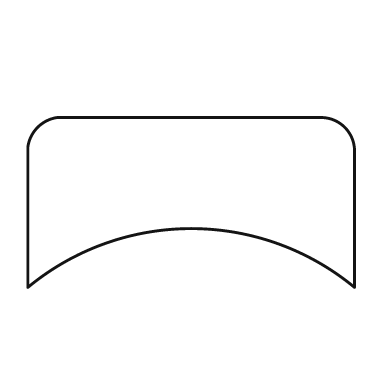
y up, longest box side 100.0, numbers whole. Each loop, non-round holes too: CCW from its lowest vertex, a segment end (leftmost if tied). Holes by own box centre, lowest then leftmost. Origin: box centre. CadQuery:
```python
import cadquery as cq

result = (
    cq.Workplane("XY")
    .moveTo(-50.0, -26.0)
    .threePointArc((0.0, -8.0), (50.0, -26.0))
    .lineTo(50.0, 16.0)
    .threePointArc((47.0, 23.0), (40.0, 26.0))
    .lineTo(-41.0, 26.0)
    .threePointArc((-47.0, 23.0), (-50.0, 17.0))
    .close()
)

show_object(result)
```